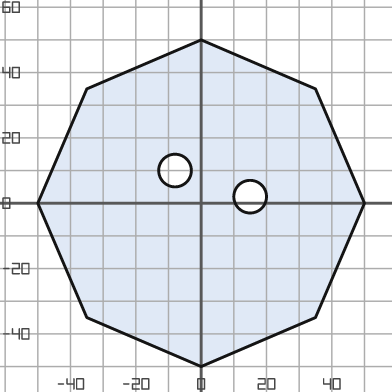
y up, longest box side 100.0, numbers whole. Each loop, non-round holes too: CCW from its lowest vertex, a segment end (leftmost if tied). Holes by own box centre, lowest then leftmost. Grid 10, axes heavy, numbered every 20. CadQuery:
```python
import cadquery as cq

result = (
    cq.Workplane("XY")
    .moveTo(0.0, -50.0)
    .lineTo(35.0, -35.0)
    .lineTo(50.0, 0.0)
    .lineTo(35.0, 35.0)
    .lineTo(0.0, 50.0)
    .lineTo(-35.0, 35.0)
    .lineTo(-50.0, 0.0)
    .lineTo(-35.0, -35.0)
    .close()
    .moveTo(15.0, 2.0)
    .circle(5.0)
    .moveTo(-8.0, 10.0)
    .circle(5.0)
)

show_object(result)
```